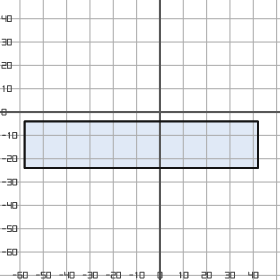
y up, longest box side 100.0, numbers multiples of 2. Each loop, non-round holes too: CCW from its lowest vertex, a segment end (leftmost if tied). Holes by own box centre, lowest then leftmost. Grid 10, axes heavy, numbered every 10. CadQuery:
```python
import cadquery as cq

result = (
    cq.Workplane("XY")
    .moveTo(-58.0, -24.0)
    .lineTo(42.0, -24.0)
    .lineTo(42.0, -4.0)
    .lineTo(-58.0, -4.0)
    .close()
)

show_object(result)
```